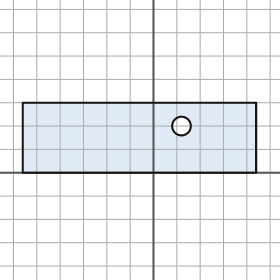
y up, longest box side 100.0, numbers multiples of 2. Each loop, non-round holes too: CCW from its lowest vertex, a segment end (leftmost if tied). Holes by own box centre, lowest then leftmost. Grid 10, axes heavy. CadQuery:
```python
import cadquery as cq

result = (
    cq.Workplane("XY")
    .moveTo(-56.0, 0.0)
    .lineTo(44.0, 0.0)
    .lineTo(44.0, 30.0)
    .lineTo(-56.0, 30.0)
    .close()
    .moveTo(12.0, 20.0)
    .circle(4.0)
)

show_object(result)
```